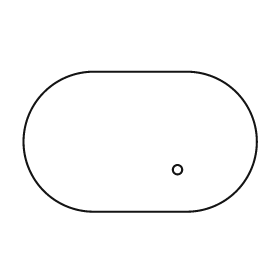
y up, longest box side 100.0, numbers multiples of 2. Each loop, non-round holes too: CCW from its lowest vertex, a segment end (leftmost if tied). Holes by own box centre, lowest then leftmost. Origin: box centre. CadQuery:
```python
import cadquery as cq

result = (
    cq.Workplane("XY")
    .moveTo(-20.0, -30.0)
    .lineTo(20.0, -30.0)
    .threePointArc((50.0, 0.0), (20.0, 30.0))
    .lineTo(-20.0, 30.0)
    .threePointArc((-50.0, 0.0), (-20.0, -30.0))
    .close()
    .moveTo(16.0, -12.0)
    .circle(2.0)
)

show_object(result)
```